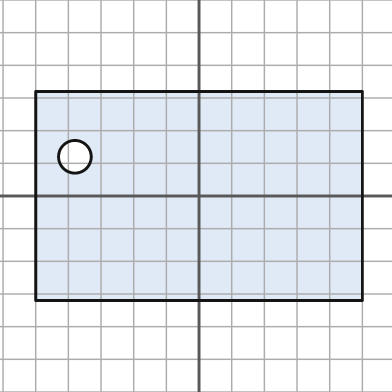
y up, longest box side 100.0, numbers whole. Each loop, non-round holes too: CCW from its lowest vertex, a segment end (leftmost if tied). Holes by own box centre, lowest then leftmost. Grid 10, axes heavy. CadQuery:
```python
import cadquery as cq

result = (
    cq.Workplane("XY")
    .moveTo(-50.0, -32.0)
    .lineTo(50.0, -32.0)
    .lineTo(50.0, 32.0)
    .lineTo(-50.0, 32.0)
    .close()
    .moveTo(-38.0, 12.0)
    .circle(5.0)
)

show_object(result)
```